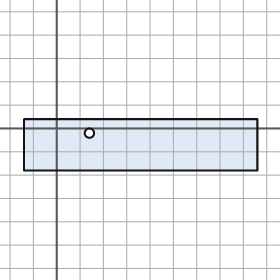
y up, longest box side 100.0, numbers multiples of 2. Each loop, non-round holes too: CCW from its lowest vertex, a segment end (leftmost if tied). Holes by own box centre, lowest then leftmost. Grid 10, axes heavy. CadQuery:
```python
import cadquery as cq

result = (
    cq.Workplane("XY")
    .moveTo(-14.0, -18.0)
    .lineTo(86.0, -18.0)
    .lineTo(86.0, 4.0)
    .lineTo(-14.0, 4.0)
    .close()
    .moveTo(14.0, -2.0)
    .circle(2.0)
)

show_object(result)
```